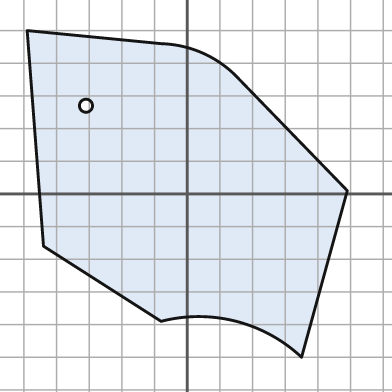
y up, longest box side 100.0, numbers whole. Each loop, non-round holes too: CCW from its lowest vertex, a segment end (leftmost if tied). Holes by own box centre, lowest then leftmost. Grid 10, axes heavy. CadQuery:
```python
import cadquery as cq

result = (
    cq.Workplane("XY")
    .moveTo(35.0, -50.0)
    .lineTo(49.0, 1.0)
    .lineTo(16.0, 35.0)
    .threePointArc((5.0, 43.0), (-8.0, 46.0))
    .lineTo(-49.0, 50.0)
    .lineTo(-44.0, -16.0)
    .lineTo(-8.0, -39.0)
    .threePointArc((15.0, -39.0), (35.0, -50.0))
    .close()
    .moveTo(-31.0, 27.0)
    .circle(2.0)
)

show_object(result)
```